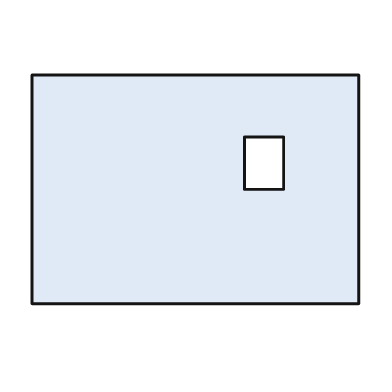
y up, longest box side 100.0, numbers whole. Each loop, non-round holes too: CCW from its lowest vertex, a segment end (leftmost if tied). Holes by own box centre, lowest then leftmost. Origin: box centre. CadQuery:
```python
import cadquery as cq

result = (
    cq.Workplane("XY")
    .moveTo(-50.0, -35.0)
    .lineTo(50.0, -35.0)
    .lineTo(50.0, 35.0)
    .lineTo(-50.0, 35.0)
    .close()
    .moveTo(15.0, 0.0)
    .lineTo(27.0, 0.0)
    .lineTo(27.0, 16.0)
    .lineTo(15.0, 16.0)
    .close()
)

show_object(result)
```